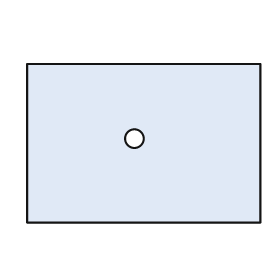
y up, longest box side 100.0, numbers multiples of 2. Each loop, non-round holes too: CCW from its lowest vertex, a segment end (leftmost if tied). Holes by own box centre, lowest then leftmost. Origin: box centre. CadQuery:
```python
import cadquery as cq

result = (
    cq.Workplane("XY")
    .moveTo(-50.0, -34.0)
    .lineTo(50.0, -34.0)
    .lineTo(50.0, 34.0)
    .lineTo(-50.0, 34.0)
    .close()
    .moveTo(-4.0, 2.0)
    .circle(4.0)
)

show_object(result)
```